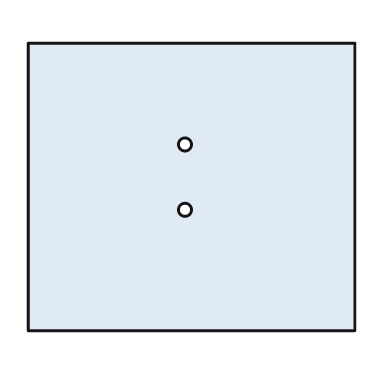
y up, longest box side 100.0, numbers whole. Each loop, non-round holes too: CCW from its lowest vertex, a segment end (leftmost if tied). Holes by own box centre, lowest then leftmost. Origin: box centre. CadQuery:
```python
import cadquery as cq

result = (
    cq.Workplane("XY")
    .moveTo(-50.0, -44.0)
    .lineTo(50.0, -44.0)
    .lineTo(50.0, 44.0)
    .lineTo(-50.0, 44.0)
    .close()
    .moveTo(-2.0, -7.0)
    .circle(2.0)
    .moveTo(-2.0, 13.0)
    .circle(2.0)
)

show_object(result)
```